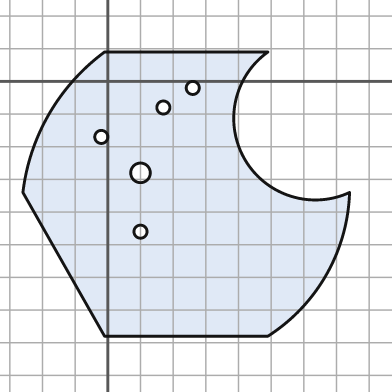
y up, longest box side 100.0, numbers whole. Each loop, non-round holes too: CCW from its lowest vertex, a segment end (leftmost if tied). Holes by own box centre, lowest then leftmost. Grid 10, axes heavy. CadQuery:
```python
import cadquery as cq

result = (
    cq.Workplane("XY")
    .moveTo(-1.0, -78.0)
    .lineTo(49.0, -78.0)
    .threePointArc((67.0, -59.0), (74.0, -34.0))
    .threePointArc((42.0, -24.0), (49.0, 9.0))
    .lineTo(-1.0, 9.0)
    .threePointArc((-18.0, -10.0), (-26.0, -34.0))
    .close()
    .moveTo(10.0, -46.0)
    .circle(2.0)
    .moveTo(10.0, -28.0)
    .circle(3.0)
    .moveTo(-2.0, -17.0)
    .circle(2.0)
    .moveTo(17.0, -8.0)
    .circle(2.0)
    .moveTo(26.0, -2.0)
    .circle(2.0)
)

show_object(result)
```